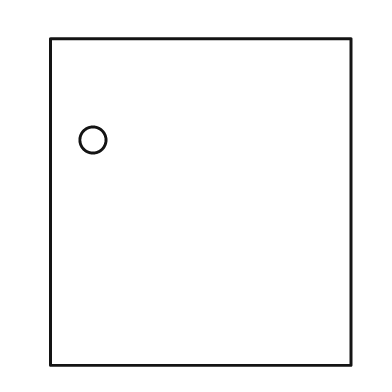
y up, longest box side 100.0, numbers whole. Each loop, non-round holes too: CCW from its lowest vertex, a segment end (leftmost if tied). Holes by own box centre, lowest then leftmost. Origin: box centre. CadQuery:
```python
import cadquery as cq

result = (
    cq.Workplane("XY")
    .moveTo(-46.0, -50.0)
    .lineTo(46.0, -50.0)
    .lineTo(46.0, 50.0)
    .lineTo(-46.0, 50.0)
    .close()
    .moveTo(-33.0, 19.0)
    .circle(4.0)
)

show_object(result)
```